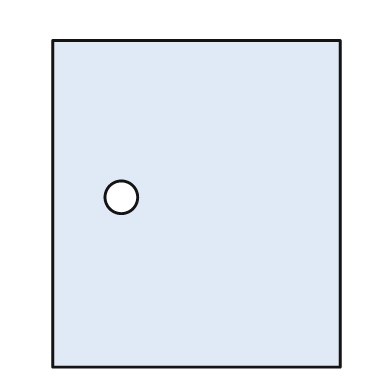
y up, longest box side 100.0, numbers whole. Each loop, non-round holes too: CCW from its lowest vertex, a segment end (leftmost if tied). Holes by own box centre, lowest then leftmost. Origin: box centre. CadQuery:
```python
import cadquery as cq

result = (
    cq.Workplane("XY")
    .moveTo(-44.0, -50.0)
    .lineTo(44.0, -50.0)
    .lineTo(44.0, 50.0)
    .lineTo(-44.0, 50.0)
    .close()
    .moveTo(-23.0, 2.0)
    .circle(5.0)
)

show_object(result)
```